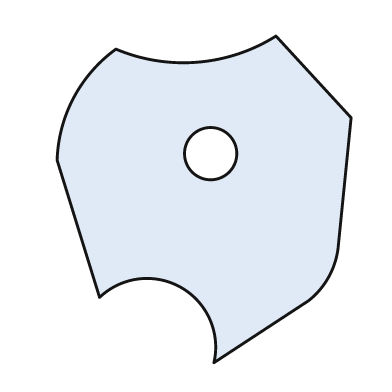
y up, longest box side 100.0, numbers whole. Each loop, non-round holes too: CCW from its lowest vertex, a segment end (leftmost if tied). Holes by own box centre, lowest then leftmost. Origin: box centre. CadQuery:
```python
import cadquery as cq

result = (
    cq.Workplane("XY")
    .moveTo(3.0, -50.0)
    .lineTo(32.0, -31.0)
    .threePointArc((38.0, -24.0), (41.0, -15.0))
    .lineTo(45.0, 25.0)
    .lineTo(22.0, 50.0)
    .threePointArc((-2.0, 42.0), (-27.0, 46.0))
    .threePointArc((-40.0, 31.0), (-45.0, 12.0))
    .lineTo(-32.0, -30.0)
    .threePointArc((-7.0, -27.0), (3.0, -50.0))
    .close()
    .moveTo(2.0, 14.0)
    .circle(8.0)
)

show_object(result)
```